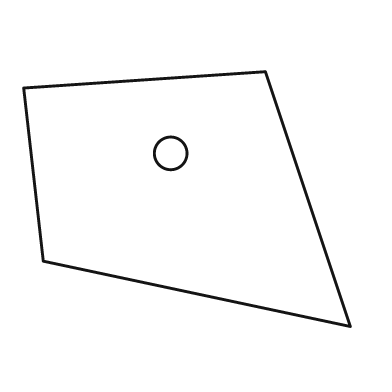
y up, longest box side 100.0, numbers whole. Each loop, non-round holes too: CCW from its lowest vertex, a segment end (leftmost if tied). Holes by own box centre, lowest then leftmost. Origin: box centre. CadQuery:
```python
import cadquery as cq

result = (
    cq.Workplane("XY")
    .moveTo(50.0, -39.0)
    .lineTo(24.0, 39.0)
    .lineTo(-50.0, 34.0)
    .lineTo(-44.0, -19.0)
    .close()
    .moveTo(-5.0, 14.0)
    .circle(5.0)
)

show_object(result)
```